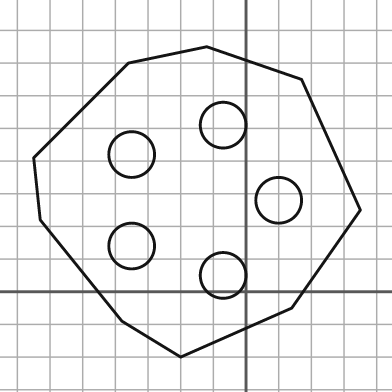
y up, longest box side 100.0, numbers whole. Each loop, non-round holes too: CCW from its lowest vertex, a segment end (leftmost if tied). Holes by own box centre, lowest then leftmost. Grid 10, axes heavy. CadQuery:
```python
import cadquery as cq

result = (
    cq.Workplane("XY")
    .moveTo(-20.0, -20.0)
    .lineTo(14.0, -5.0)
    .lineTo(35.0, 25.0)
    .lineTo(17.0, 65.0)
    .lineTo(-12.0, 75.0)
    .lineTo(-36.0, 70.0)
    .lineTo(-65.0, 41.0)
    .lineTo(-63.0, 22.0)
    .lineTo(-38.0, -9.0)
    .close()
    .moveTo(-7.0, 5.0)
    .circle(7.0)
    .moveTo(-35.0, 14.0)
    .circle(7.0)
    .moveTo(10.0, 28.0)
    .circle(7.0)
    .moveTo(-35.0, 42.0)
    .circle(7.0)
    .moveTo(-7.0, 51.0)
    .circle(7.0)
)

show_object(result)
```